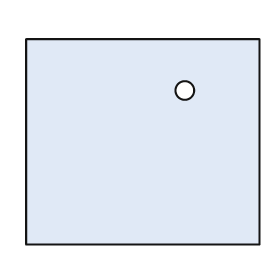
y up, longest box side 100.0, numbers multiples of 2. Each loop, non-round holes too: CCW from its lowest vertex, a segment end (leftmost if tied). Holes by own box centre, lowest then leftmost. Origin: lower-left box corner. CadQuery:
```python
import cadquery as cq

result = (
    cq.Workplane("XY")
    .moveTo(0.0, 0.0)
    .lineTo(100.0, 0.0)
    .lineTo(100.0, 88.0)
    .lineTo(0.0, 88.0)
    .close()
    .moveTo(68.0, 66.0)
    .circle(4.0)
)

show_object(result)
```